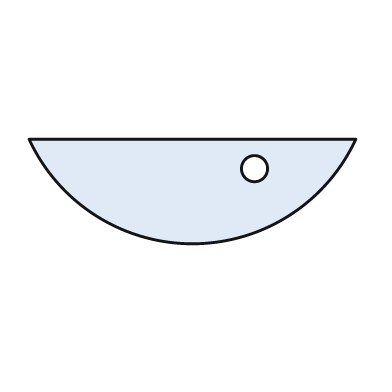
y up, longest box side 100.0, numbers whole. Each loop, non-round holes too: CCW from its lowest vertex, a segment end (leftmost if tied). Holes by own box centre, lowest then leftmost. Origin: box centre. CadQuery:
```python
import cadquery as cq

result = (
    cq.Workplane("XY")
    .moveTo(-50.0, 16.0)
    .threePointArc((0.0, -16.0), (50.0, 16.0))
    .close()
    .moveTo(19.0, 7.0)
    .circle(4.0)
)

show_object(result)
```